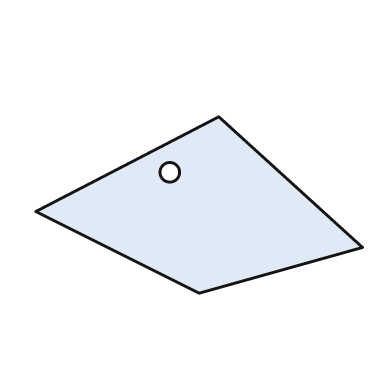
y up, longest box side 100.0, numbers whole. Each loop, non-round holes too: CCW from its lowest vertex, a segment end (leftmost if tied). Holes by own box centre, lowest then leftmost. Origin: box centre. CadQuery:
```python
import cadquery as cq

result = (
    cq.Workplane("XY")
    .moveTo(0.0, -27.0)
    .lineTo(50.0, -13.0)
    .lineTo(6.0, 27.0)
    .lineTo(-50.0, -2.0)
    .close()
    .moveTo(-9.0, 10.0)
    .circle(3.0)
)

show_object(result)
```